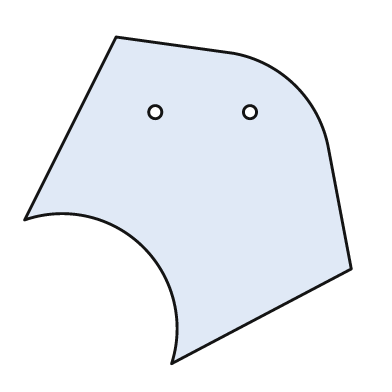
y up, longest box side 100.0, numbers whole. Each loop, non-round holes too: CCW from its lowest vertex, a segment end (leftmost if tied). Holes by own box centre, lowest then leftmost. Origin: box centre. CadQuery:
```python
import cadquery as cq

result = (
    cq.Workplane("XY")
    .moveTo(-5.0, -50.0)
    .lineTo(50.0, -21.0)
    .lineTo(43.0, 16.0)
    .threePointArc((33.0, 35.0), (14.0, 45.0))
    .lineTo(-22.0, 50.0)
    .lineTo(-50.0, -6.0)
    .threePointArc((-14.0, -14.0), (-5.0, -50.0))
    .close()
    .moveTo(-10.0, 27.0)
    .circle(2.0)
    .moveTo(19.0, 27.0)
    .circle(2.0)
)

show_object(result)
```